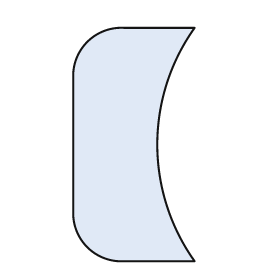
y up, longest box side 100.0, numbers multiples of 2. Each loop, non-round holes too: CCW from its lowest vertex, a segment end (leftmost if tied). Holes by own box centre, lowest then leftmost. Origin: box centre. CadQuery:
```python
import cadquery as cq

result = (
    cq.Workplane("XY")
    .moveTo(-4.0, -50.0)
    .lineTo(26.0, -50.0)
    .threePointArc((10.0, 0.0), (26.0, 50.0))
    .lineTo(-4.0, 50.0)
    .threePointArc((-20.0, 44.0), (-26.0, 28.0))
    .lineTo(-26.0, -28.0)
    .threePointArc((-20.0, -44.0), (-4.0, -50.0))
    .close()
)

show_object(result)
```